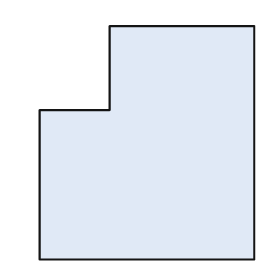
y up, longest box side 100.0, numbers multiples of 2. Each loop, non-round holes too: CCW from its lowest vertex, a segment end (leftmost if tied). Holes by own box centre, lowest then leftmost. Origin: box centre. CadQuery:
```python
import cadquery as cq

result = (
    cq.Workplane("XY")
    .moveTo(-46.0, -50.0)
    .lineTo(46.0, -50.0)
    .lineTo(46.0, 50.0)
    .lineTo(-16.0, 50.0)
    .lineTo(-16.0, 14.0)
    .lineTo(-46.0, 14.0)
    .close()
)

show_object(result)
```